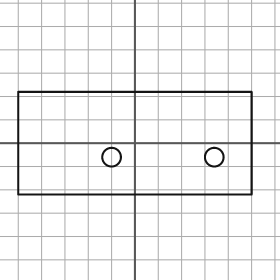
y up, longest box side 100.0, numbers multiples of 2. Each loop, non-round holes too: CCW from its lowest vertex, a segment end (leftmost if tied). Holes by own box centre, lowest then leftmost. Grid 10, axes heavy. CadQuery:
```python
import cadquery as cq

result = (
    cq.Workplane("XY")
    .moveTo(-50.0, -22.0)
    .lineTo(50.0, -22.0)
    .lineTo(50.0, 22.0)
    .lineTo(-50.0, 22.0)
    .close()
    .moveTo(-10.0, -6.0)
    .circle(4.0)
    .moveTo(34.0, -6.0)
    .circle(4.0)
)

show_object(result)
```